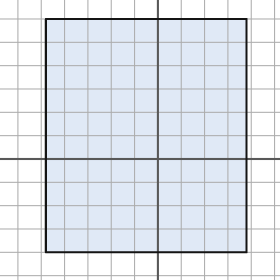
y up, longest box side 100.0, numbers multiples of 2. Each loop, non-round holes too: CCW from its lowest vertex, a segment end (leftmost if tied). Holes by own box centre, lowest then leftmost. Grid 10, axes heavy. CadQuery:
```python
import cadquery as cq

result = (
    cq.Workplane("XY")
    .moveTo(-48.0, -40.0)
    .lineTo(38.0, -40.0)
    .lineTo(38.0, 60.0)
    .lineTo(-48.0, 60.0)
    .close()
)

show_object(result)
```